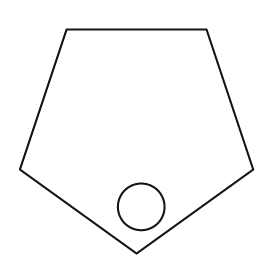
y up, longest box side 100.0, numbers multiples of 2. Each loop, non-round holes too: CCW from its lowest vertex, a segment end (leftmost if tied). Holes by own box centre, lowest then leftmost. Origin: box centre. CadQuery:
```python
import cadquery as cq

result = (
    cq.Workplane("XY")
    .moveTo(0.0, -48.0)
    .lineTo(50.0, -12.0)
    .lineTo(30.0, 48.0)
    .lineTo(-30.0, 48.0)
    .lineTo(-50.0, -12.0)
    .close()
    .moveTo(2.0, -28.0)
    .circle(10.0)
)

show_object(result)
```